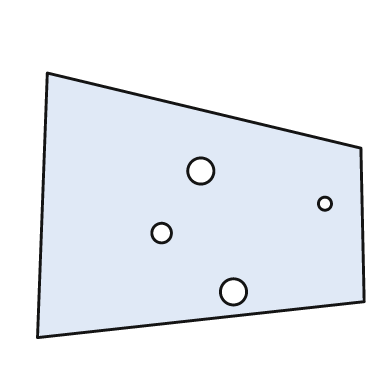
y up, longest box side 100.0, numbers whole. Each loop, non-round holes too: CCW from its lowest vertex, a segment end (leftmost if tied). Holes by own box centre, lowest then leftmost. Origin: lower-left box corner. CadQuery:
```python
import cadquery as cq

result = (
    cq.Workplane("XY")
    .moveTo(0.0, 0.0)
    .lineTo(100.0, 11.0)
    .lineTo(99.0, 58.0)
    .lineTo(3.0, 81.0)
    .close()
    .moveTo(60.0, 14.0)
    .circle(4.0)
    .moveTo(38.0, 32.0)
    .circle(3.0)
    .moveTo(88.0, 41.0)
    .circle(2.0)
    .moveTo(50.0, 51.0)
    .circle(4.0)
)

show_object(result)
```